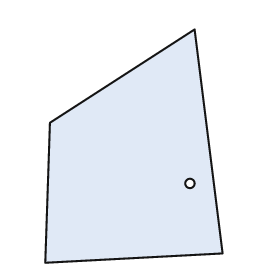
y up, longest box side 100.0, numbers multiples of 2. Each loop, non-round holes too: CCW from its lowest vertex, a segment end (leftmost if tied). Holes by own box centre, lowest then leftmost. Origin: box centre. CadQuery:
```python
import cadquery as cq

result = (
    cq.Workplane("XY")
    .moveTo(-38.0, -50.0)
    .lineTo(38.0, -46.0)
    .lineTo(26.0, 50.0)
    .lineTo(-36.0, 10.0)
    .close()
    .moveTo(24.0, -16.0)
    .circle(2.0)
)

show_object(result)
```